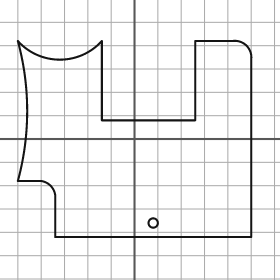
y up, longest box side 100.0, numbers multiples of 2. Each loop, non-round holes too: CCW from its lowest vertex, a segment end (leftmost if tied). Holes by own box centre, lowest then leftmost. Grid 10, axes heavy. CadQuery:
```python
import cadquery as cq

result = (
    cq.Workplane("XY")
    .moveTo(-34.0, -42.0)
    .lineTo(50.0, -42.0)
    .lineTo(50.0, 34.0)
    .threePointArc((48.0, 40.0), (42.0, 42.0))
    .lineTo(26.0, 42.0)
    .lineTo(26.0, 8.0)
    .lineTo(-14.0, 8.0)
    .lineTo(-14.0, 42.0)
    .threePointArc((-32.0, 34.0), (-50.0, 42.0))
    .threePointArc((-46.0, 12.0), (-50.0, -18.0))
    .lineTo(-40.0, -18.0)
    .threePointArc((-36.0, -20.0), (-34.0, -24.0))
    .close()
    .moveTo(8.0, -36.0)
    .circle(2.0)
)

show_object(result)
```